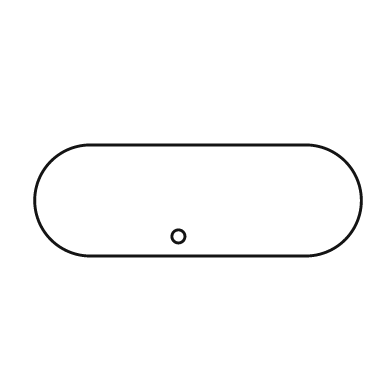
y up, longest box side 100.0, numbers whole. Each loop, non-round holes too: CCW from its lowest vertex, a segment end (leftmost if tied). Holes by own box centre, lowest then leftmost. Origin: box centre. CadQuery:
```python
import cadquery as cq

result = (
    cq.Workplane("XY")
    .moveTo(-33.0, -17.0)
    .lineTo(33.0, -17.0)
    .threePointArc((50.0, 0.0), (33.0, 17.0))
    .lineTo(-33.0, 17.0)
    .threePointArc((-50.0, 0.0), (-33.0, -17.0))
    .close()
    .moveTo(-6.0, -11.0)
    .circle(2.0)
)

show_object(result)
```